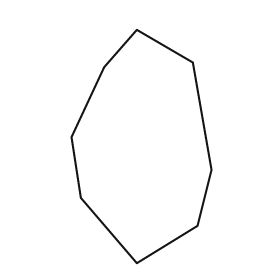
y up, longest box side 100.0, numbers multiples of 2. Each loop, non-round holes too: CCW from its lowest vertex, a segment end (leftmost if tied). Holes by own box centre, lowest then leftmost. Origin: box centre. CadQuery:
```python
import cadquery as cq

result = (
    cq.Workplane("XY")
    .moveTo(-2.0, -50.0)
    .lineTo(24.0, -34.0)
    .lineTo(30.0, -10.0)
    .lineTo(22.0, 36.0)
    .lineTo(-2.0, 50.0)
    .lineTo(-16.0, 34.0)
    .lineTo(-30.0, 4.0)
    .lineTo(-26.0, -22.0)
    .close()
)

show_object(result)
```